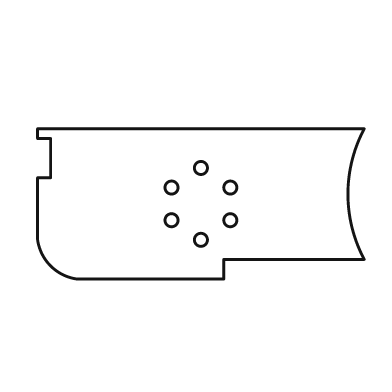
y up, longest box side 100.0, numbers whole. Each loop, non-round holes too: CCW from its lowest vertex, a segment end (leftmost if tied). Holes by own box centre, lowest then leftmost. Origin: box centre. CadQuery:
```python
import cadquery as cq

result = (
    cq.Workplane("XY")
    .moveTo(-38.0, -23.0)
    .lineTo(7.0, -23.0)
    .lineTo(7.0, -17.0)
    .lineTo(50.0, -17.0)
    .threePointArc((45.0, 3.0), (50.0, 23.0))
    .lineTo(-50.0, 23.0)
    .lineTo(-50.0, 20.0)
    .lineTo(-46.0, 20.0)
    .lineTo(-46.0, 8.0)
    .lineTo(-50.0, 8.0)
    .lineTo(-50.0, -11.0)
    .threePointArc((-46.0, -19.0), (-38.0, -23.0))
    .close()
    .moveTo(0.0, -11.0)
    .circle(2.0)
    .moveTo(-9.0, -5.0)
    .circle(2.0)
    .moveTo(9.0, -5.0)
    .circle(2.0)
    .moveTo(-9.0, 5.0)
    .circle(2.0)
    .moveTo(9.0, 5.0)
    .circle(2.0)
    .moveTo(0.0, 11.0)
    .circle(2.0)
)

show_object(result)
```